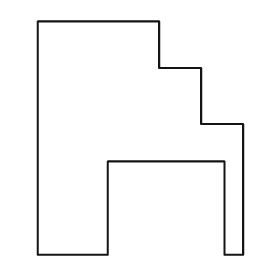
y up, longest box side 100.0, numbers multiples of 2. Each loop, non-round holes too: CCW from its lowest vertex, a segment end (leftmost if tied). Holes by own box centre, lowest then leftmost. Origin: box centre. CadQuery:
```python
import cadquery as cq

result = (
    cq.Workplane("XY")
    .moveTo(-44.0, -50.0)
    .lineTo(-14.0, -50.0)
    .lineTo(-14.0, -10.0)
    .lineTo(36.0, -10.0)
    .lineTo(36.0, -50.0)
    .lineTo(44.0, -50.0)
    .lineTo(44.0, 6.0)
    .lineTo(26.0, 6.0)
    .lineTo(26.0, 30.0)
    .lineTo(8.0, 30.0)
    .lineTo(8.0, 50.0)
    .lineTo(-44.0, 50.0)
    .close()
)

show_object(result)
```